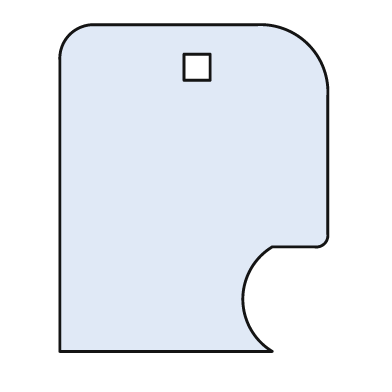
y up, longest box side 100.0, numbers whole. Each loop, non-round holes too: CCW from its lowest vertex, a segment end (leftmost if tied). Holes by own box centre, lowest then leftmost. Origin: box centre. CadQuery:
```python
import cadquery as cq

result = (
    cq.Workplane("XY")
    .moveTo(-41.0, -50.0)
    .lineTo(24.0, -50.0)
    .threePointArc((15.0, -34.0), (24.0, -18.0))
    .lineTo(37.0, -18.0)
    .threePointArc((40.0, -17.0), (41.0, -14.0))
    .lineTo(41.0, 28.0)
    .threePointArc((35.0, 44.0), (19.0, 50.0))
    .lineTo(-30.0, 50.0)
    .threePointArc((-38.0, 47.0), (-41.0, 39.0))
    .close()
    .moveTo(-3.0, 33.0)
    .lineTo(5.0, 33.0)
    .lineTo(5.0, 41.0)
    .lineTo(-3.0, 41.0)
    .close()
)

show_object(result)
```